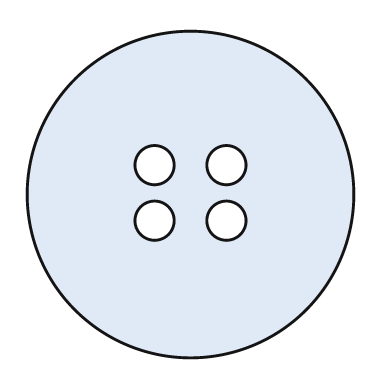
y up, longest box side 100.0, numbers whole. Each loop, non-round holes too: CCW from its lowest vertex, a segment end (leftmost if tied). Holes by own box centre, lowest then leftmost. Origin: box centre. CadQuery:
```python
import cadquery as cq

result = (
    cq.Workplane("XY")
    .moveTo(0.0, 0.0)
    .circle(50.0)
    .moveTo(-11.0, -8.0)
    .circle(6.0)
    .moveTo(11.0, -8.0)
    .circle(6.0)
    .moveTo(-11.0, 9.0)
    .circle(6.0)
    .moveTo(11.0, 9.0)
    .circle(6.0)
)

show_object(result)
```